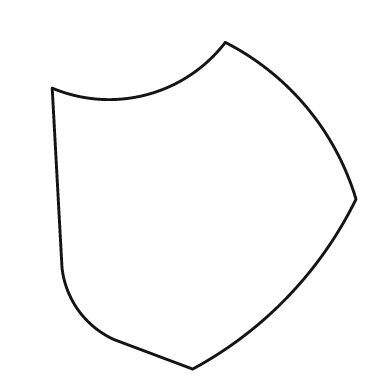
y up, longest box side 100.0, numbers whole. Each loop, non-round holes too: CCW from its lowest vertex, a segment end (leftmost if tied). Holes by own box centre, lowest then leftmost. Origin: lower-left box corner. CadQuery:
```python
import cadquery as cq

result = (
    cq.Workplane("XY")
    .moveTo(43.0, 0.0)
    .threePointArc((72.0, 22.0), (93.0, 52.0))
    .threePointArc((78.0, 80.0), (53.0, 100.0))
    .threePointArc((29.0, 84.0), (0.0, 86.0))
    .lineTo(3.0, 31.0)
    .threePointArc((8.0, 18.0), (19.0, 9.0))
    .close()
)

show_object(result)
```